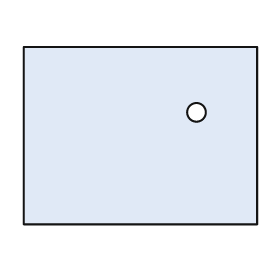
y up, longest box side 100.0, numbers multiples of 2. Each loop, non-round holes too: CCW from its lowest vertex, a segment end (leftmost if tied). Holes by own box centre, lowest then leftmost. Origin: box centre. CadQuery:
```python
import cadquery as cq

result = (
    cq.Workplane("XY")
    .moveTo(-50.0, -38.0)
    .lineTo(50.0, -38.0)
    .lineTo(50.0, 38.0)
    .lineTo(-50.0, 38.0)
    .close()
    .moveTo(24.0, 10.0)
    .circle(4.0)
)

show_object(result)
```